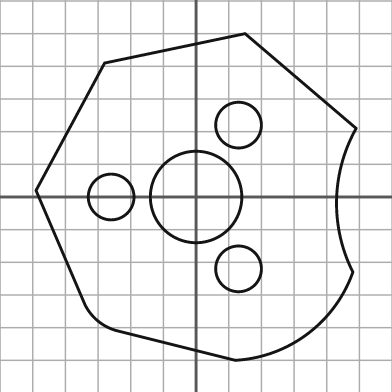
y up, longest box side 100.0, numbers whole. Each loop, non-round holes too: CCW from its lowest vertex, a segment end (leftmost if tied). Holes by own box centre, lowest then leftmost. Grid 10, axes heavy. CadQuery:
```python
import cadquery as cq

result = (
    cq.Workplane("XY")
    .moveTo(12.0, -50.0)
    .threePointArc((34.0, -42.0), (48.0, -23.0))
    .threePointArc((43.0, -1.0), (49.0, 21.0))
    .lineTo(15.0, 50.0)
    .lineTo(-28.0, 41.0)
    .lineTo(-49.0, 2.0)
    .lineTo(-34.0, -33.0)
    .threePointArc((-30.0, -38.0), (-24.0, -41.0))
    .close()
    .moveTo(13.0, -22.0)
    .circle(7.0)
    .moveTo(-26.0, 0.0)
    .circle(7.0)
    .moveTo(0.0, 0.0)
    .circle(14.0)
    .moveTo(13.0, 22.0)
    .circle(7.0)
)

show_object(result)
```